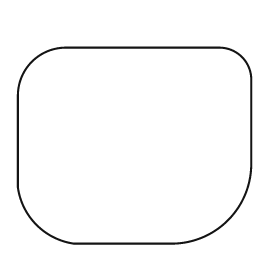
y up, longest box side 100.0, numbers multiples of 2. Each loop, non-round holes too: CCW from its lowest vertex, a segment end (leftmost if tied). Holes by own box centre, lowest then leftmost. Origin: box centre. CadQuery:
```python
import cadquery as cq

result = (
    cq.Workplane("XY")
    .moveTo(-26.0, -42.0)
    .lineTo(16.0, -42.0)
    .threePointArc((40.0, -32.0), (50.0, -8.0))
    .lineTo(50.0, 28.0)
    .threePointArc((46.0, 38.0), (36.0, 42.0))
    .lineTo(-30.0, 42.0)
    .threePointArc((-44.0, 36.0), (-50.0, 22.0))
    .lineTo(-50.0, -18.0)
    .threePointArc((-42.0, -34.0), (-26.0, -42.0))
    .close()
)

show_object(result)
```